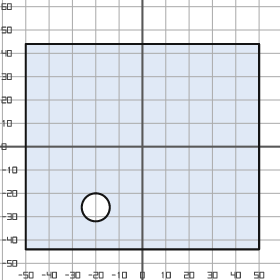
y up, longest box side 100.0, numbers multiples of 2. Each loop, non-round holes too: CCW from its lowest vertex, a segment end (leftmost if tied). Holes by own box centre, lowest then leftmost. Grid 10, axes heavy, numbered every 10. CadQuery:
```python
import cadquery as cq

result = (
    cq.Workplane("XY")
    .moveTo(-50.0, -44.0)
    .lineTo(50.0, -44.0)
    .lineTo(50.0, 44.0)
    .lineTo(-50.0, 44.0)
    .close()
    .moveTo(-20.0, -26.0)
    .circle(6.0)
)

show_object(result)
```